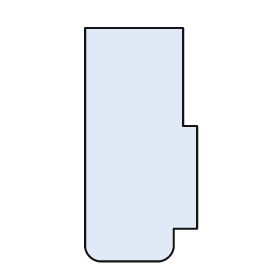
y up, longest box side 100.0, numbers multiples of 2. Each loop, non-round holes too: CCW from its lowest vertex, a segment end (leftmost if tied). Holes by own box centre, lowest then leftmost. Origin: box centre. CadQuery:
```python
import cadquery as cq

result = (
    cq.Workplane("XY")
    .moveTo(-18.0, -50.0)
    .lineTo(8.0, -50.0)
    .threePointArc((12.0, -48.0), (14.0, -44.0))
    .lineTo(14.0, -36.0)
    .lineTo(24.0, -36.0)
    .lineTo(24.0, 8.0)
    .lineTo(18.0, 8.0)
    .lineTo(18.0, 50.0)
    .lineTo(-24.0, 50.0)
    .lineTo(-24.0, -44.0)
    .threePointArc((-22.0, -48.0), (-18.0, -50.0))
    .close()
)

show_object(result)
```